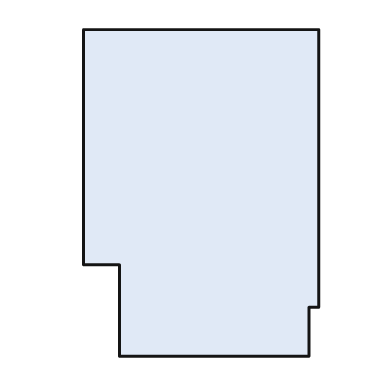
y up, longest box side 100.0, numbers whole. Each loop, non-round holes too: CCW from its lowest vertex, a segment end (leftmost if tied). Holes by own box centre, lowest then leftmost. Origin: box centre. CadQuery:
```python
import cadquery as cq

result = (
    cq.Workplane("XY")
    .moveTo(-25.0, -50.0)
    .lineTo(33.0, -50.0)
    .lineTo(33.0, -35.0)
    .lineTo(36.0, -35.0)
    .lineTo(36.0, 50.0)
    .lineTo(-36.0, 50.0)
    .lineTo(-36.0, -22.0)
    .lineTo(-25.0, -22.0)
    .close()
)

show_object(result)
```